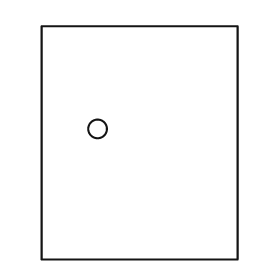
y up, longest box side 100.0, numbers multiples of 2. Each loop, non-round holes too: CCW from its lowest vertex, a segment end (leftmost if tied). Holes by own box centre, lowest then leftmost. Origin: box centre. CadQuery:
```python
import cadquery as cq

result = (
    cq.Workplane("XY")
    .moveTo(-42.0, -50.0)
    .lineTo(42.0, -50.0)
    .lineTo(42.0, 50.0)
    .lineTo(-42.0, 50.0)
    .close()
    .moveTo(-18.0, 6.0)
    .circle(4.0)
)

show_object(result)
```